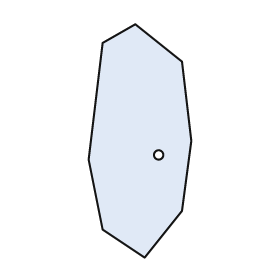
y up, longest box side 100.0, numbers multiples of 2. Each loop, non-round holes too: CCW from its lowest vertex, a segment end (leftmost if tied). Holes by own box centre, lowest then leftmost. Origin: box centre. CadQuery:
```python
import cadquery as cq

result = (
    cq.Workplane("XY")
    .moveTo(2.0, -50.0)
    .lineTo(18.0, -30.0)
    .lineTo(22.0, 0.0)
    .lineTo(18.0, 34.0)
    .lineTo(-2.0, 50.0)
    .lineTo(-16.0, 42.0)
    .lineTo(-22.0, -8.0)
    .lineTo(-16.0, -38.0)
    .close()
    .moveTo(8.0, -6.0)
    .circle(2.0)
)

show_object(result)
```